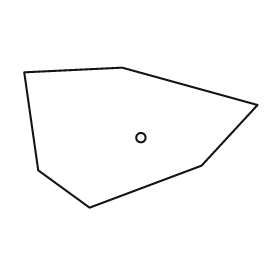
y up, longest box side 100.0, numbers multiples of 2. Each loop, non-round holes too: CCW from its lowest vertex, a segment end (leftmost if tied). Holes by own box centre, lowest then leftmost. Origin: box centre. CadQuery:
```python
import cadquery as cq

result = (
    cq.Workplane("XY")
    .moveTo(-22.0, -30.0)
    .lineTo(26.0, -12.0)
    .lineTo(50.0, 14.0)
    .lineTo(-8.0, 30.0)
    .lineTo(-50.0, 28.0)
    .lineTo(-44.0, -14.0)
    .close()
    .moveTo(0.0, 0.0)
    .circle(2.0)
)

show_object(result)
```